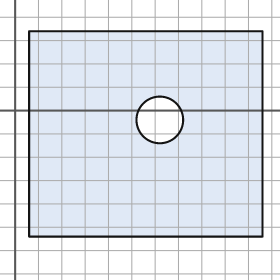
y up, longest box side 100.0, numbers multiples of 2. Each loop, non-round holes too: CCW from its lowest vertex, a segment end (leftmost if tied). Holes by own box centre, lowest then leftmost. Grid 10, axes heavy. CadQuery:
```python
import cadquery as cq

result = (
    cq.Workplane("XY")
    .moveTo(6.0, -54.0)
    .lineTo(106.0, -54.0)
    .lineTo(106.0, 34.0)
    .lineTo(6.0, 34.0)
    .close()
    .moveTo(62.0, -4.0)
    .circle(10.0)
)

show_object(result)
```